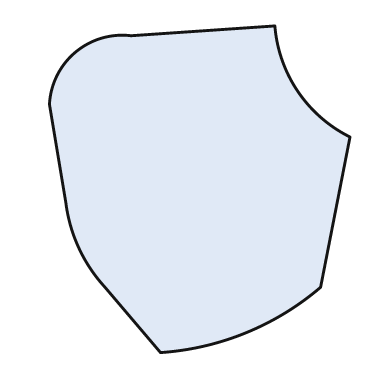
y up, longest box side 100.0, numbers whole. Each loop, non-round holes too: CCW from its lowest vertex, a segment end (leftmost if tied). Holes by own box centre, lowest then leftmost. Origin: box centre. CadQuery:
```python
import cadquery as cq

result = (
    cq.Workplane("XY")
    .moveTo(-12.0, -50.0)
    .threePointArc((14.0, -44.0), (37.0, -30.0))
    .lineTo(46.0, 16.0)
    .threePointArc((30.0, 30.0), (23.0, 50.0))
    .lineTo(-21.0, 47.0)
    .threePointArc((-38.0, 42.0), (-46.0, 26.0))
    .lineTo(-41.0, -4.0)
    .threePointArc((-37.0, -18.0), (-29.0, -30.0))
    .close()
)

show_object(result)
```